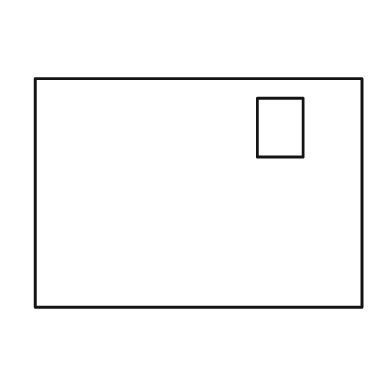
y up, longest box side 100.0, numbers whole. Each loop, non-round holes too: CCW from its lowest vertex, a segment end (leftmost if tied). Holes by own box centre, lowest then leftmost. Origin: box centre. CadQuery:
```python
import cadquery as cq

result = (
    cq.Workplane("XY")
    .moveTo(-50.0, -35.0)
    .lineTo(50.0, -35.0)
    .lineTo(50.0, 35.0)
    .lineTo(-50.0, 35.0)
    .close()
    .moveTo(18.0, 11.0)
    .lineTo(32.0, 11.0)
    .lineTo(32.0, 29.0)
    .lineTo(18.0, 29.0)
    .close()
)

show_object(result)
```